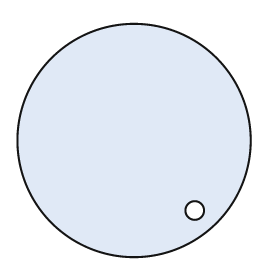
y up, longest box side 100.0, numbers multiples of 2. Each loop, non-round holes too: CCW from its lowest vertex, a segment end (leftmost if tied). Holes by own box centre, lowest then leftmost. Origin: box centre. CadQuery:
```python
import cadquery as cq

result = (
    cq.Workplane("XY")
    .moveTo(0.0, 0.0)
    .circle(50.0)
    .moveTo(26.0, -30.0)
    .circle(4.0)
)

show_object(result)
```